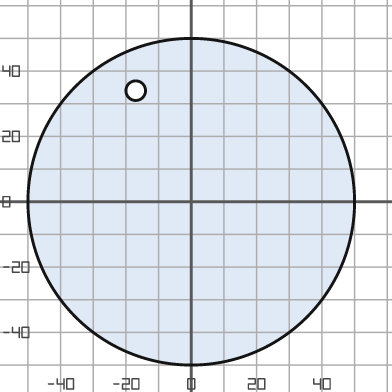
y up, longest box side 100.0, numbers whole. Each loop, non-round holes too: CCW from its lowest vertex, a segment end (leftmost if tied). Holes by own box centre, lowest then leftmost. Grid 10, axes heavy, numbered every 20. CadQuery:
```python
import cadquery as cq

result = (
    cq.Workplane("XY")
    .moveTo(0.0, 0.0)
    .circle(50.0)
    .moveTo(-17.0, 34.0)
    .circle(3.0)
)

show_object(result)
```